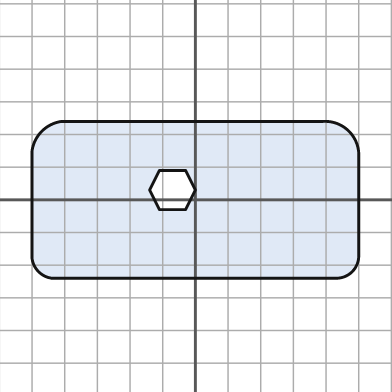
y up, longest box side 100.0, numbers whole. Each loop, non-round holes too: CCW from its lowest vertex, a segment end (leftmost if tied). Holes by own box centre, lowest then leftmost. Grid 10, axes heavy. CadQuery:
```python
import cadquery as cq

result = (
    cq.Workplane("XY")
    .moveTo(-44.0, -24.0)
    .lineTo(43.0, -24.0)
    .threePointArc((48.0, -22.0), (50.0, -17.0))
    .lineTo(50.0, 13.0)
    .threePointArc((47.0, 21.0), (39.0, 24.0))
    .lineTo(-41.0, 24.0)
    .threePointArc((-47.0, 21.0), (-50.0, 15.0))
    .lineTo(-50.0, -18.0)
    .threePointArc((-48.0, -22.0), (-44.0, -24.0))
    .close()
    .moveTo(-11.0, -3.0)
    .lineTo(-3.0, -3.0)
    .lineTo(0.0, 3.0)
    .lineTo(-3.0, 9.0)
    .lineTo(-11.0, 9.0)
    .lineTo(-14.0, 3.0)
    .close()
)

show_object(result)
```